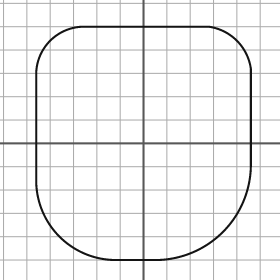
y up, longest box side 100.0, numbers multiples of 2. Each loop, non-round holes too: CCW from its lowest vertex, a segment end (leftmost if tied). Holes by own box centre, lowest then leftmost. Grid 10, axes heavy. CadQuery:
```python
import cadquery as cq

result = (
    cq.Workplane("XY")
    .moveTo(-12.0, -50.0)
    .lineTo(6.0, -50.0)
    .threePointArc((34.0, -38.0), (46.0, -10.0))
    .lineTo(46.0, 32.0)
    .threePointArc((40.0, 44.0), (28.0, 50.0))
    .lineTo(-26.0, 50.0)
    .threePointArc((-40.0, 44.0), (-46.0, 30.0))
    .lineTo(-46.0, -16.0)
    .threePointArc((-36.0, -40.0), (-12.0, -50.0))
    .close()
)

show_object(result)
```